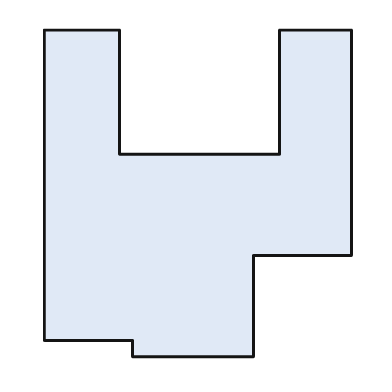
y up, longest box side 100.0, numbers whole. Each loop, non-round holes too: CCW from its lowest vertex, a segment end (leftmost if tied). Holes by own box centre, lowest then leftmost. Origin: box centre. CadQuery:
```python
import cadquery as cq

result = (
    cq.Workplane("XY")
    .moveTo(-20.0, -50.0)
    .lineTo(17.0, -50.0)
    .lineTo(17.0, -19.0)
    .lineTo(47.0, -19.0)
    .lineTo(47.0, 50.0)
    .lineTo(25.0, 50.0)
    .lineTo(25.0, 12.0)
    .lineTo(-24.0, 12.0)
    .lineTo(-24.0, 50.0)
    .lineTo(-47.0, 50.0)
    .lineTo(-47.0, -45.0)
    .lineTo(-20.0, -45.0)
    .close()
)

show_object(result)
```